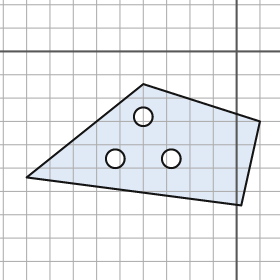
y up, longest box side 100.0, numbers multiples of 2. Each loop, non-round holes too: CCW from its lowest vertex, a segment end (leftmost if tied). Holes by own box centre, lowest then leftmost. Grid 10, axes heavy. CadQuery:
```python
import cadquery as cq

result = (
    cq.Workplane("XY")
    .moveTo(2.0, -66.0)
    .lineTo(10.0, -30.0)
    .lineTo(-40.0, -14.0)
    .lineTo(-90.0, -54.0)
    .close()
    .moveTo(-52.0, -46.0)
    .circle(4.0)
    .moveTo(-28.0, -46.0)
    .circle(4.0)
    .moveTo(-40.0, -28.0)
    .circle(4.0)
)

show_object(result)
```